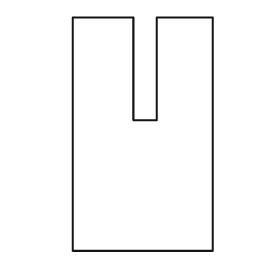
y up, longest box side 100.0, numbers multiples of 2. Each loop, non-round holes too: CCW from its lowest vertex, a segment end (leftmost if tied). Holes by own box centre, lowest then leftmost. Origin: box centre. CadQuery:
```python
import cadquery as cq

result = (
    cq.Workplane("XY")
    .moveTo(-30.0, -50.0)
    .lineTo(30.0, -50.0)
    .lineTo(30.0, 50.0)
    .lineTo(6.0, 50.0)
    .lineTo(6.0, 6.0)
    .lineTo(-4.0, 6.0)
    .lineTo(-4.0, 50.0)
    .lineTo(-30.0, 50.0)
    .close()
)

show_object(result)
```